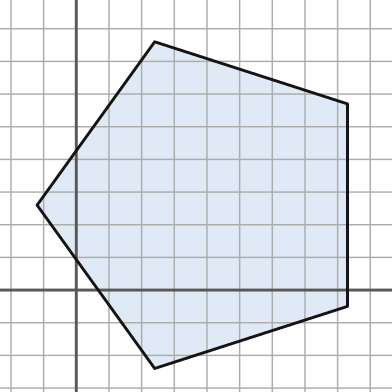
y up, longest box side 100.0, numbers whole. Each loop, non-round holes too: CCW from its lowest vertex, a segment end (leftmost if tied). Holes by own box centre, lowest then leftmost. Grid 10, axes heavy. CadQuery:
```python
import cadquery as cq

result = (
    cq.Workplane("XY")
    .moveTo(24.0, -24.0)
    .lineTo(83.0, -5.0)
    .lineTo(83.0, 57.0)
    .lineTo(24.0, 76.0)
    .lineTo(-12.0, 26.0)
    .close()
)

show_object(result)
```